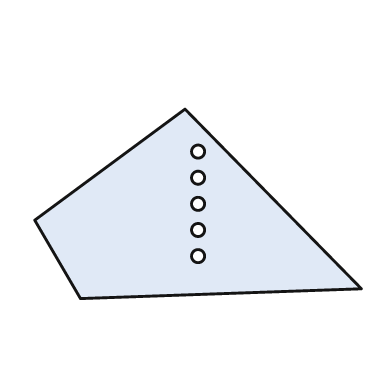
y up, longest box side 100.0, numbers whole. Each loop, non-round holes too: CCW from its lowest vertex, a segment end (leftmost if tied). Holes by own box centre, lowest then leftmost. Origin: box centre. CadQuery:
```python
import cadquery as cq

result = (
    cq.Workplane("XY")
    .moveTo(-36.0, -29.0)
    .lineTo(50.0, -26.0)
    .lineTo(-4.0, 29.0)
    .lineTo(-50.0, -5.0)
    .close()
    .moveTo(0.0, -16.0)
    .circle(2.0)
    .moveTo(0.0, -8.0)
    .circle(2.0)
    .moveTo(0.0, 0.0)
    .circle(2.0)
    .moveTo(0.0, 8.0)
    .circle(2.0)
    .moveTo(0.0, 16.0)
    .circle(2.0)
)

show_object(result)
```